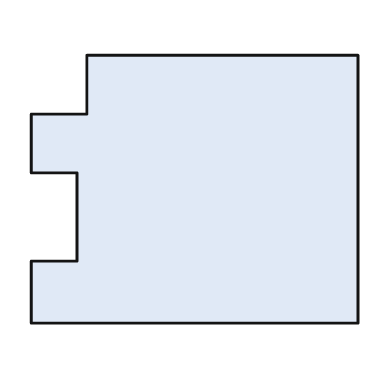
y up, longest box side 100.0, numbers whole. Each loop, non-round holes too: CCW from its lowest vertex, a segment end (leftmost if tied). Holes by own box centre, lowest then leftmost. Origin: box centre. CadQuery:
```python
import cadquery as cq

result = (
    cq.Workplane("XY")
    .moveTo(-50.0, -41.0)
    .lineTo(50.0, -41.0)
    .lineTo(50.0, 41.0)
    .lineTo(-33.0, 41.0)
    .lineTo(-33.0, 23.0)
    .lineTo(-50.0, 23.0)
    .lineTo(-50.0, 5.0)
    .lineTo(-36.0, 5.0)
    .lineTo(-36.0, -22.0)
    .lineTo(-50.0, -22.0)
    .close()
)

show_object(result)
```